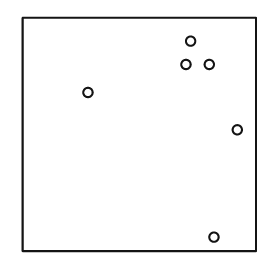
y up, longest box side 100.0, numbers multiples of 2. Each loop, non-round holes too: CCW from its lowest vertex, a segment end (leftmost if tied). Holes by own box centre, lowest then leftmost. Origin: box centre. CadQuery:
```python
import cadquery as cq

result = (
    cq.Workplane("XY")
    .moveTo(-50.0, -50.0)
    .lineTo(50.0, -50.0)
    .lineTo(50.0, 50.0)
    .lineTo(-50.0, 50.0)
    .close()
    .moveTo(32.0, -44.0)
    .circle(2.0)
    .moveTo(42.0, 2.0)
    .circle(2.0)
    .moveTo(-22.0, 18.0)
    .circle(2.0)
    .moveTo(20.0, 30.0)
    .circle(2.0)
    .moveTo(30.0, 30.0)
    .circle(2.0)
    .moveTo(22.0, 40.0)
    .circle(2.0)
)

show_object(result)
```